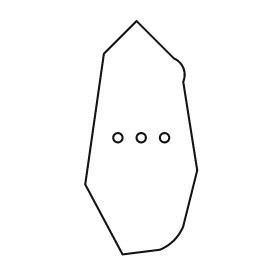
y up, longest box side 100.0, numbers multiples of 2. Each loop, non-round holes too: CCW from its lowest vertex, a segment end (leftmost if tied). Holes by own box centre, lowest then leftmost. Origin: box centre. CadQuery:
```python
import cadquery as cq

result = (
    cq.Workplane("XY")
    .moveTo(-8.0, -50.0)
    .lineTo(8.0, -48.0)
    .threePointArc((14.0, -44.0), (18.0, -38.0))
    .lineTo(24.0, -14.0)
    .lineTo(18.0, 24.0)
    .threePointArc((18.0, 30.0), (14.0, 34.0))
    .lineTo(-2.0, 50.0)
    .lineTo(-16.0, 36.0)
    .lineTo(-24.0, -20.0)
    .close()
    .moveTo(-10.0, 0.0)
    .circle(2.0)
    .moveTo(0.0, 0.0)
    .circle(2.0)
    .moveTo(10.0, 0.0)
    .circle(2.0)
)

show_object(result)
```